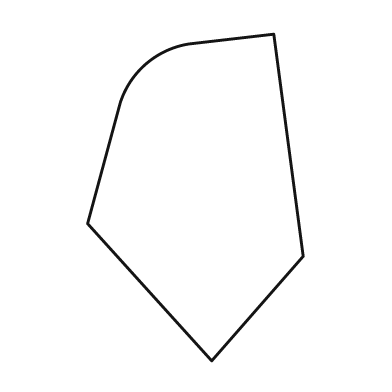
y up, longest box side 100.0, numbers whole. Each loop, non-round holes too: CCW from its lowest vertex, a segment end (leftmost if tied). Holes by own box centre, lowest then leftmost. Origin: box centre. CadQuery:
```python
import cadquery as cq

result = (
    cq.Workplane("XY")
    .moveTo(5.0, -50.0)
    .lineTo(33.0, -18.0)
    .lineTo(24.0, 50.0)
    .lineTo(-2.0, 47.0)
    .threePointArc((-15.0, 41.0), (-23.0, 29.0))
    .lineTo(-33.0, -8.0)
    .close()
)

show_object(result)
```